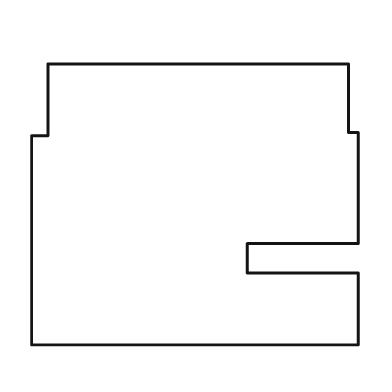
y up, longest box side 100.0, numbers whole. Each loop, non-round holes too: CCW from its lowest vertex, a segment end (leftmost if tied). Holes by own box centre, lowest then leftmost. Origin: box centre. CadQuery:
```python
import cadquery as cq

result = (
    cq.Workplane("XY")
    .moveTo(-50.0, -43.0)
    .lineTo(50.0, -43.0)
    .lineTo(50.0, -21.0)
    .lineTo(16.0, -21.0)
    .lineTo(16.0, -12.0)
    .lineTo(50.0, -12.0)
    .lineTo(50.0, 22.0)
    .lineTo(47.0, 22.0)
    .lineTo(47.0, 43.0)
    .lineTo(-45.0, 43.0)
    .lineTo(-45.0, 21.0)
    .lineTo(-50.0, 21.0)
    .close()
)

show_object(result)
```